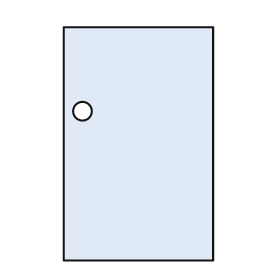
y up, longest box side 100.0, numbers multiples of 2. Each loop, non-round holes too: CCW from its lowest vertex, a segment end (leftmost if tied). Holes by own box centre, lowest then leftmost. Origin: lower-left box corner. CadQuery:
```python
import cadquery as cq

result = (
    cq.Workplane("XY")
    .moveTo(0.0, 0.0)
    .lineTo(64.0, 0.0)
    .lineTo(64.0, 100.0)
    .lineTo(0.0, 100.0)
    .close()
    .moveTo(8.0, 64.0)
    .circle(4.0)
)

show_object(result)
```